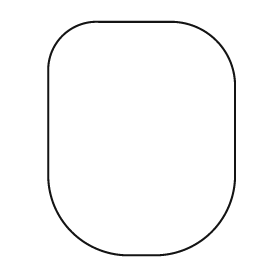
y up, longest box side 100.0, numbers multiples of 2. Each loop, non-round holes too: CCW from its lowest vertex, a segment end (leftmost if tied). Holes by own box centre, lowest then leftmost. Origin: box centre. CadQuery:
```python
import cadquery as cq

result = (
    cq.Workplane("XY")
    .moveTo(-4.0, -50.0)
    .lineTo(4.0, -50.0)
    .threePointArc((30.0, -40.0), (40.0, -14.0))
    .lineTo(40.0, 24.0)
    .threePointArc((32.0, 42.0), (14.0, 50.0))
    .lineTo(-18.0, 50.0)
    .threePointArc((-34.0, 44.0), (-40.0, 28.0))
    .lineTo(-40.0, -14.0)
    .threePointArc((-30.0, -40.0), (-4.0, -50.0))
    .close()
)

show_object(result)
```